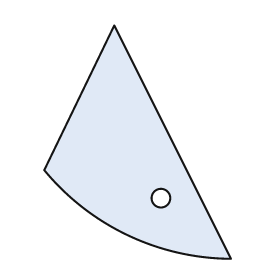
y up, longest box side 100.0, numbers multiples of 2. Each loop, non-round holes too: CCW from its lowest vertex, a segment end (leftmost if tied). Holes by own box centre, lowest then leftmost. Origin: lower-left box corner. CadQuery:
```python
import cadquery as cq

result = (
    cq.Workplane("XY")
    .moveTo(80.0, 0.0)
    .lineTo(30.0, 100.0)
    .lineTo(0.0, 38.0)
    .threePointArc((36.0, 10.0), (80.0, 0.0))
    .close()
    .moveTo(50.0, 26.0)
    .circle(4.0)
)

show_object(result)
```